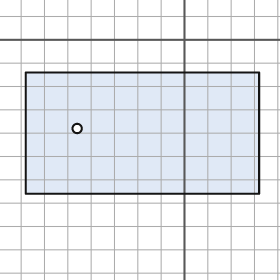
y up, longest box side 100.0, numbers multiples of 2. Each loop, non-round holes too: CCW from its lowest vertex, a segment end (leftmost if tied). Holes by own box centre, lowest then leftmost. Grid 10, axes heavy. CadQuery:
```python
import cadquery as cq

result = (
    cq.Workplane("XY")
    .moveTo(-68.0, -66.0)
    .lineTo(32.0, -66.0)
    .lineTo(32.0, -14.0)
    .lineTo(-68.0, -14.0)
    .close()
    .moveTo(-46.0, -38.0)
    .circle(2.0)
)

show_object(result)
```